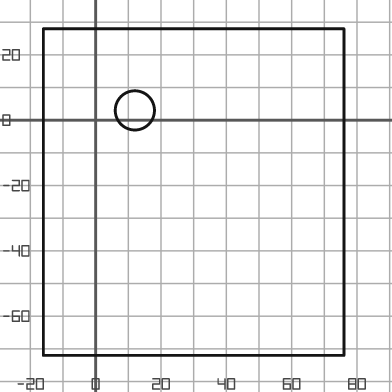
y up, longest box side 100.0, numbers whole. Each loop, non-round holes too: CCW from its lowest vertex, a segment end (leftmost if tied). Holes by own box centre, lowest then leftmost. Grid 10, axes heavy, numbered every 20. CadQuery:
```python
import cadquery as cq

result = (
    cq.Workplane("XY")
    .moveTo(-16.0, -72.0)
    .lineTo(76.0, -72.0)
    .lineTo(76.0, 28.0)
    .lineTo(-16.0, 28.0)
    .close()
    .moveTo(12.0, 3.0)
    .circle(6.0)
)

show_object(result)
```